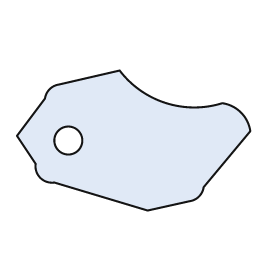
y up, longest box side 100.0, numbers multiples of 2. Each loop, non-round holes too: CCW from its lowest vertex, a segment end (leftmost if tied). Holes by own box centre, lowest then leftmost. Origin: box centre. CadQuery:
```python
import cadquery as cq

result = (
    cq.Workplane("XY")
    .moveTo(6.0, -30.0)
    .lineTo(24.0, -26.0)
    .threePointArc((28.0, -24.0), (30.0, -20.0))
    .lineTo(50.0, 4.0)
    .threePointArc((46.0, 12.0), (38.0, 16.0))
    .threePointArc((14.0, 16.0), (-6.0, 30.0))
    .lineTo(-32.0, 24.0)
    .threePointArc((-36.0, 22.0), (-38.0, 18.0))
    .lineTo(-50.0, 2.0)
    .lineTo(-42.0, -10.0)
    .threePointArc((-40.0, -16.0), (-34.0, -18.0))
    .close()
    .moveTo(-28.0, 0.0)
    .circle(6.0)
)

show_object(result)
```